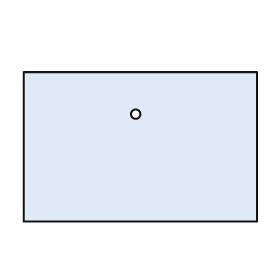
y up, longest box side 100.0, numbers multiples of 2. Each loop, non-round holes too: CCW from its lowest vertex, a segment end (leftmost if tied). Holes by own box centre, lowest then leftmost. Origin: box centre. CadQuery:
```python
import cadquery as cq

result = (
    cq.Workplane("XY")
    .moveTo(-50.0, -32.0)
    .lineTo(50.0, -32.0)
    .lineTo(50.0, 32.0)
    .lineTo(-50.0, 32.0)
    .close()
    .moveTo(-2.0, 14.0)
    .circle(2.0)
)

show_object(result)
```